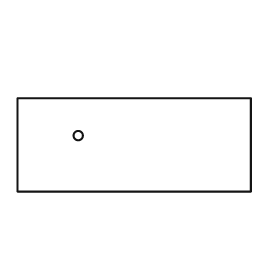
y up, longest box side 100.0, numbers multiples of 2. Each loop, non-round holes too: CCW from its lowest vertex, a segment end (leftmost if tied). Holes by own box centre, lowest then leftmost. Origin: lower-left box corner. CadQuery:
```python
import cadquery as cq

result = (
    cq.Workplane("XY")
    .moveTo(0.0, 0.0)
    .lineTo(100.0, 0.0)
    .lineTo(100.0, 40.0)
    .lineTo(0.0, 40.0)
    .close()
    .moveTo(26.0, 24.0)
    .circle(2.0)
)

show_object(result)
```